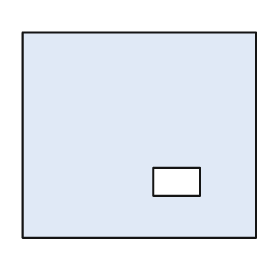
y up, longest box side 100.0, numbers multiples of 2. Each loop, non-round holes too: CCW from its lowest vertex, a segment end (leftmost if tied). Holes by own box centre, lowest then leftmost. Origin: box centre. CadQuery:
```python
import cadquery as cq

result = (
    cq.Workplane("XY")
    .moveTo(-50.0, -44.0)
    .lineTo(50.0, -44.0)
    .lineTo(50.0, 44.0)
    .lineTo(-50.0, 44.0)
    .close()
    .moveTo(6.0, -26.0)
    .lineTo(26.0, -26.0)
    .lineTo(26.0, -14.0)
    .lineTo(6.0, -14.0)
    .close()
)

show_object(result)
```